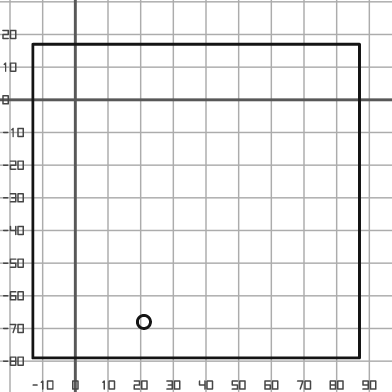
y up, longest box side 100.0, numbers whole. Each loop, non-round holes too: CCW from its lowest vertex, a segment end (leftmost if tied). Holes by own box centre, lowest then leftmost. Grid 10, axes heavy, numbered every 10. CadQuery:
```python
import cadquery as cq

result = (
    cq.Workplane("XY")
    .moveTo(-13.0, -79.0)
    .lineTo(87.0, -79.0)
    .lineTo(87.0, 17.0)
    .lineTo(-13.0, 17.0)
    .close()
    .moveTo(21.0, -68.0)
    .circle(2.0)
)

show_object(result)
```